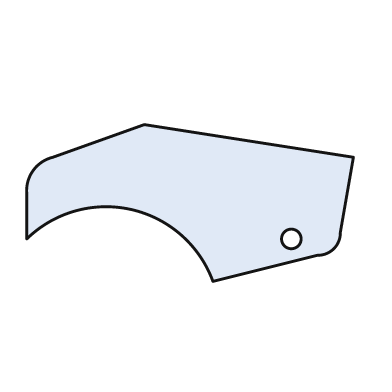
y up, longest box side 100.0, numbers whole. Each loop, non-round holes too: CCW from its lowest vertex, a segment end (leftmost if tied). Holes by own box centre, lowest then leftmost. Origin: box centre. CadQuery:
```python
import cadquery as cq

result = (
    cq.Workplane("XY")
    .moveTo(7.0, -24.0)
    .lineTo(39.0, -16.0)
    .threePointArc((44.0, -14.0), (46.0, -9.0))
    .lineTo(50.0, 14.0)
    .lineTo(-14.0, 24.0)
    .lineTo(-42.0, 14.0)
    .threePointArc((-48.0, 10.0), (-50.0, 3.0))
    .lineTo(-50.0, -11.0)
    .threePointArc((-18.0, -2.0), (7.0, -24.0))
    .close()
    .moveTo(31.0, -11.0)
    .circle(3.0)
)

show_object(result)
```